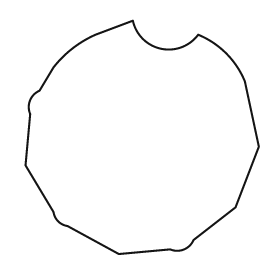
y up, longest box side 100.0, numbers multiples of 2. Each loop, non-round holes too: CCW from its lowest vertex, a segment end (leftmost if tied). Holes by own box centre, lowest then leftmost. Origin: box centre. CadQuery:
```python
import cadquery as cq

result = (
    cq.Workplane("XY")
    .moveTo(-10.0, -50.0)
    .lineTo(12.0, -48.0)
    .threePointArc((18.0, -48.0), (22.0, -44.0))
    .lineTo(40.0, -30.0)
    .lineTo(50.0, -4.0)
    .lineTo(44.0, 24.0)
    .threePointArc((36.0, 36.0), (24.0, 44.0))
    .threePointArc((8.0, 38.0), (-4.0, 50.0))
    .lineTo(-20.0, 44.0)
    .threePointArc((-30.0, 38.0), (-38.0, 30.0))
    .lineTo(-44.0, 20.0)
    .threePointArc((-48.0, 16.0), (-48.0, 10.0))
    .lineTo(-50.0, -12.0)
    .lineTo(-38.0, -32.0)
    .threePointArc((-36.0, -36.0), (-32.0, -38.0))
    .close()
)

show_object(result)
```